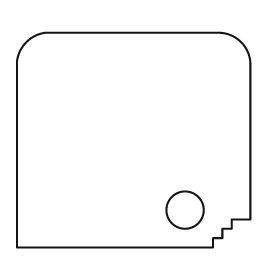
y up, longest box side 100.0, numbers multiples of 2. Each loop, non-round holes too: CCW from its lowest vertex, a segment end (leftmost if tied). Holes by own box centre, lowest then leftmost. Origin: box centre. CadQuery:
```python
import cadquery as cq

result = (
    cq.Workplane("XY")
    .moveTo(-50.0, -46.0)
    .lineTo(34.0, -46.0)
    .lineTo(34.0, -42.0)
    .lineTo(38.0, -42.0)
    .lineTo(38.0, -38.0)
    .lineTo(42.0, -38.0)
    .lineTo(42.0, -34.0)
    .lineTo(50.0, -34.0)
    .lineTo(50.0, 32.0)
    .threePointArc((46.0, 42.0), (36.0, 46.0))
    .lineTo(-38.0, 46.0)
    .threePointArc((-46.0, 42.0), (-50.0, 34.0))
    .close()
    .moveTo(22.0, -30.0)
    .circle(8.0)
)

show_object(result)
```